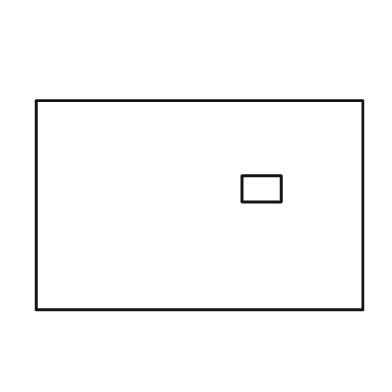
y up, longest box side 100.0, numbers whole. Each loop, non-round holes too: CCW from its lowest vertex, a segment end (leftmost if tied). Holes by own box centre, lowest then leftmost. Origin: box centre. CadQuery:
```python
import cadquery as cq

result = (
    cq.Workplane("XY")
    .moveTo(-50.0, -32.0)
    .lineTo(50.0, -32.0)
    .lineTo(50.0, 32.0)
    .lineTo(-50.0, 32.0)
    .close()
    .moveTo(13.0, 1.0)
    .lineTo(25.0, 1.0)
    .lineTo(25.0, 9.0)
    .lineTo(13.0, 9.0)
    .close()
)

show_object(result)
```